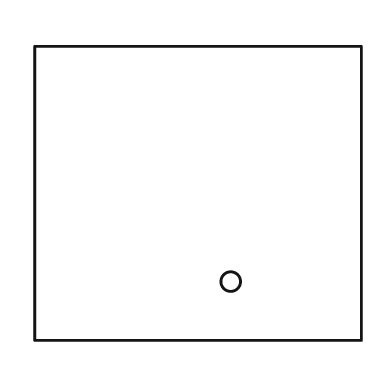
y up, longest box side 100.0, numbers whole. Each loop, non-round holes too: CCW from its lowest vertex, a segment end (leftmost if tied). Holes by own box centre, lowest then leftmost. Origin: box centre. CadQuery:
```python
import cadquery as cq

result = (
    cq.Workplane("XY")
    .moveTo(-50.0, -45.0)
    .lineTo(50.0, -45.0)
    .lineTo(50.0, 45.0)
    .lineTo(-50.0, 45.0)
    .close()
    .moveTo(10.0, -27.0)
    .circle(3.0)
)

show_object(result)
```